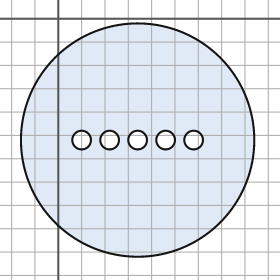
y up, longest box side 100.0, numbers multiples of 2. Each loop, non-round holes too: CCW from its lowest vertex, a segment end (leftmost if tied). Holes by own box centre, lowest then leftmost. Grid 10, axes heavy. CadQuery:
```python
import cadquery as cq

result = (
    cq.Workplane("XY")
    .moveTo(34.0, -52.0)
    .circle(50.0)
    .moveTo(10.0, -52.0)
    .circle(4.0)
    .moveTo(22.0, -52.0)
    .circle(4.0)
    .moveTo(34.0, -52.0)
    .circle(4.0)
    .moveTo(46.0, -52.0)
    .circle(4.0)
    .moveTo(58.0, -52.0)
    .circle(4.0)
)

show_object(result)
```